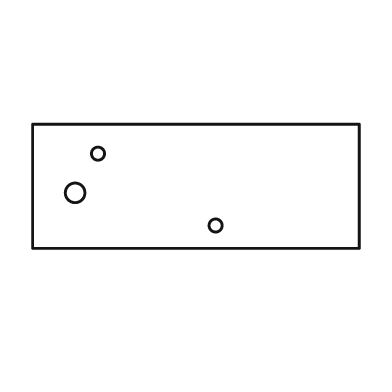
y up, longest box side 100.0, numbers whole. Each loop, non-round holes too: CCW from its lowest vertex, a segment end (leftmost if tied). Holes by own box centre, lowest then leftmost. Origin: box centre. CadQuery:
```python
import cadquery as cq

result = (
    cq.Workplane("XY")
    .moveTo(-50.0, -19.0)
    .lineTo(50.0, -19.0)
    .lineTo(50.0, 19.0)
    .lineTo(-50.0, 19.0)
    .close()
    .moveTo(6.0, -12.0)
    .circle(2.0)
    .moveTo(-37.0, -2.0)
    .circle(3.0)
    .moveTo(-30.0, 10.0)
    .circle(2.0)
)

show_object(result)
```